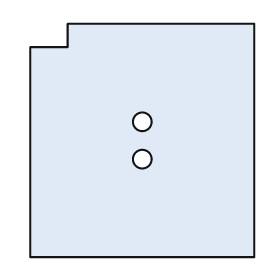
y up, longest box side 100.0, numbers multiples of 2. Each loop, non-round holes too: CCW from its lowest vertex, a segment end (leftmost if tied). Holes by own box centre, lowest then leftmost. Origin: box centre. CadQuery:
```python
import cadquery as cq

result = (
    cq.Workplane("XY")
    .moveTo(-48.0, -50.0)
    .lineTo(48.0, -50.0)
    .lineTo(48.0, 50.0)
    .lineTo(-32.0, 50.0)
    .lineTo(-32.0, 40.0)
    .lineTo(-48.0, 40.0)
    .close()
    .moveTo(0.0, -8.0)
    .circle(4.0)
    .moveTo(0.0, 8.0)
    .circle(4.0)
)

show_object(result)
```